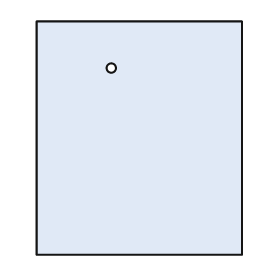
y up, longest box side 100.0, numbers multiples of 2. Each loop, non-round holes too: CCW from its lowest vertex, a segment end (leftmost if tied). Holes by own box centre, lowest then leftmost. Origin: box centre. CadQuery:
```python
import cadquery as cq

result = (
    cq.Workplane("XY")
    .moveTo(-44.0, -50.0)
    .lineTo(44.0, -50.0)
    .lineTo(44.0, 50.0)
    .lineTo(-44.0, 50.0)
    .close()
    .moveTo(-12.0, 30.0)
    .circle(2.0)
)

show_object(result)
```